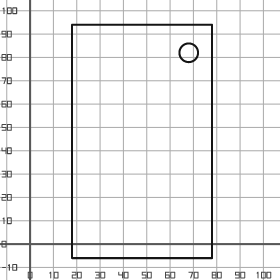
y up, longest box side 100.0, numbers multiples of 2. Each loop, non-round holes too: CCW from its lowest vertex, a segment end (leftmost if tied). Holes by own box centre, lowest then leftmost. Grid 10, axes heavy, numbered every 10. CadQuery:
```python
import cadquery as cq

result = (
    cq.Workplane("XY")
    .moveTo(18.0, -6.0)
    .lineTo(78.0, -6.0)
    .lineTo(78.0, 94.0)
    .lineTo(18.0, 94.0)
    .close()
    .moveTo(68.0, 82.0)
    .circle(4.0)
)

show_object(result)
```